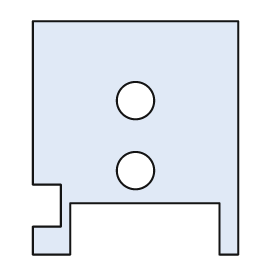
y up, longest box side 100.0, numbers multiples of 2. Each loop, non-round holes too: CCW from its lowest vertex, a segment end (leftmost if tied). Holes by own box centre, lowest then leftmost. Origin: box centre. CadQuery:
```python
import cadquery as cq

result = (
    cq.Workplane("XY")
    .moveTo(-44.0, -50.0)
    .lineTo(-28.0, -50.0)
    .lineTo(-28.0, -28.0)
    .lineTo(36.0, -28.0)
    .lineTo(36.0, -50.0)
    .lineTo(44.0, -50.0)
    .lineTo(44.0, 50.0)
    .lineTo(-44.0, 50.0)
    .lineTo(-44.0, -20.0)
    .lineTo(-32.0, -20.0)
    .lineTo(-32.0, -38.0)
    .lineTo(-44.0, -38.0)
    .close()
    .moveTo(0.0, -14.0)
    .circle(8.0)
    .moveTo(0.0, 16.0)
    .circle(8.0)
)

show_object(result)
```